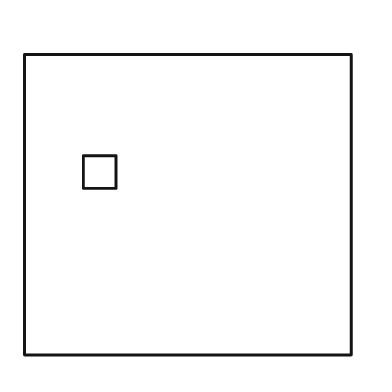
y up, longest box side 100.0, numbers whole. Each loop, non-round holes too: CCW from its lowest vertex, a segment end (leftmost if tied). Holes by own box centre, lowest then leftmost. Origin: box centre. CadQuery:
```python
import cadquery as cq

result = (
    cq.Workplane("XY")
    .moveTo(-50.0, -46.0)
    .lineTo(50.0, -46.0)
    .lineTo(50.0, 46.0)
    .lineTo(-50.0, 46.0)
    .close()
    .moveTo(-32.0, 5.0)
    .lineTo(-22.0, 5.0)
    .lineTo(-22.0, 15.0)
    .lineTo(-32.0, 15.0)
    .close()
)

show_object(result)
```